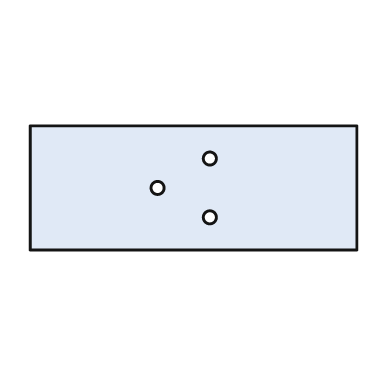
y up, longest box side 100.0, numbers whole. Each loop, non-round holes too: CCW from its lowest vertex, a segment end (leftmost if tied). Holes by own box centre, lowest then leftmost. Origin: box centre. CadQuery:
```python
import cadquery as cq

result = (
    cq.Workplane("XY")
    .moveTo(-50.0, -19.0)
    .lineTo(50.0, -19.0)
    .lineTo(50.0, 19.0)
    .lineTo(-50.0, 19.0)
    .close()
    .moveTo(5.0, -9.0)
    .circle(2.0)
    .moveTo(-11.0, 0.0)
    .circle(2.0)
    .moveTo(5.0, 9.0)
    .circle(2.0)
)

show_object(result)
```